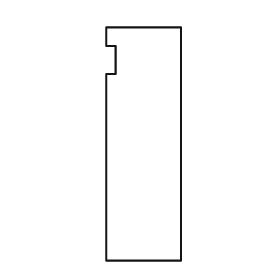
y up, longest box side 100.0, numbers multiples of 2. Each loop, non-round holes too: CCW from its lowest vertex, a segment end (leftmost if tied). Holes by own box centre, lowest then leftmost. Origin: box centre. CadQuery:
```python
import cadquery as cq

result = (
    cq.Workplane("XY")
    .moveTo(-16.0, -50.0)
    .lineTo(16.0, -50.0)
    .lineTo(16.0, 50.0)
    .lineTo(-16.0, 50.0)
    .lineTo(-16.0, 42.0)
    .lineTo(-12.0, 42.0)
    .lineTo(-12.0, 30.0)
    .lineTo(-16.0, 30.0)
    .close()
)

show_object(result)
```